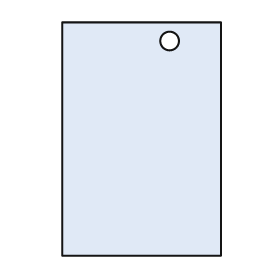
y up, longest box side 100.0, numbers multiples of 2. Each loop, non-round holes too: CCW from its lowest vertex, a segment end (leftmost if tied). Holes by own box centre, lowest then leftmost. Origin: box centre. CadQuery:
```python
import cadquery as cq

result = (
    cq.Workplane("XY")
    .moveTo(-34.0, -50.0)
    .lineTo(34.0, -50.0)
    .lineTo(34.0, 50.0)
    .lineTo(-34.0, 50.0)
    .close()
    .moveTo(12.0, 42.0)
    .circle(4.0)
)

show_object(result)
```